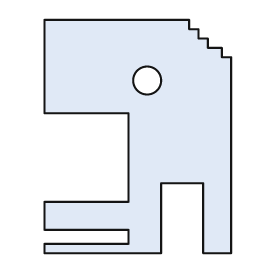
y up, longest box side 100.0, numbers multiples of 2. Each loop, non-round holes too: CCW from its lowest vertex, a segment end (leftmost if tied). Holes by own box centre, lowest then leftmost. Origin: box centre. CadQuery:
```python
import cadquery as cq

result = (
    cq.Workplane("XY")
    .moveTo(-40.0, -50.0)
    .lineTo(10.0, -50.0)
    .lineTo(10.0, -20.0)
    .lineTo(28.0, -20.0)
    .lineTo(28.0, -50.0)
    .lineTo(40.0, -50.0)
    .lineTo(40.0, 34.0)
    .lineTo(36.0, 34.0)
    .lineTo(36.0, 38.0)
    .lineTo(30.0, 38.0)
    .lineTo(30.0, 42.0)
    .lineTo(26.0, 42.0)
    .lineTo(26.0, 46.0)
    .lineTo(22.0, 46.0)
    .lineTo(22.0, 50.0)
    .lineTo(-40.0, 50.0)
    .lineTo(-40.0, 10.0)
    .lineTo(-4.0, 10.0)
    .lineTo(-4.0, -28.0)
    .lineTo(-40.0, -28.0)
    .lineTo(-40.0, -40.0)
    .lineTo(-4.0, -40.0)
    .lineTo(-4.0, -46.0)
    .lineTo(-40.0, -46.0)
    .close()
    .moveTo(4.0, 24.0)
    .circle(6.0)
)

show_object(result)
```